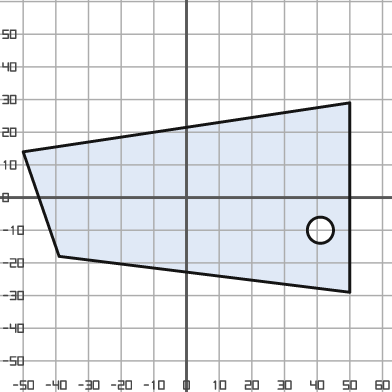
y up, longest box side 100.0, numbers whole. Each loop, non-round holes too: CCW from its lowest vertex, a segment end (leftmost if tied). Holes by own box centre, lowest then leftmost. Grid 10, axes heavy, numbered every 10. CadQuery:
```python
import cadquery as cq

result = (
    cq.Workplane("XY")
    .moveTo(50.0, -29.0)
    .lineTo(50.0, 29.0)
    .lineTo(-50.0, 14.0)
    .lineTo(-39.0, -18.0)
    .close()
    .moveTo(41.0, -10.0)
    .circle(4.0)
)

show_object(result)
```